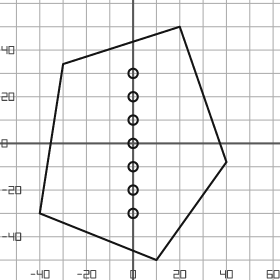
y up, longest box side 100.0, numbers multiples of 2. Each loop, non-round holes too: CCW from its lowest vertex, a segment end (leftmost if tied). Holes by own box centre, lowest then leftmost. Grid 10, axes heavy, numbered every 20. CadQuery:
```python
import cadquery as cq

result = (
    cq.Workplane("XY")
    .moveTo(10.0, -50.0)
    .lineTo(40.0, -8.0)
    .lineTo(20.0, 50.0)
    .lineTo(-30.0, 34.0)
    .lineTo(-40.0, -30.0)
    .close()
    .moveTo(0.0, -30.0)
    .circle(2.0)
    .moveTo(0.0, -20.0)
    .circle(2.0)
    .moveTo(0.0, -10.0)
    .circle(2.0)
    .moveTo(0.0, 0.0)
    .circle(2.0)
    .moveTo(0.0, 10.0)
    .circle(2.0)
    .moveTo(0.0, 20.0)
    .circle(2.0)
    .moveTo(0.0, 30.0)
    .circle(2.0)
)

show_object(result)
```